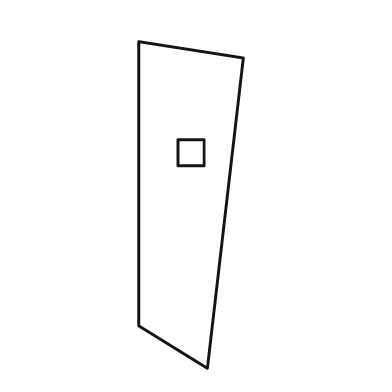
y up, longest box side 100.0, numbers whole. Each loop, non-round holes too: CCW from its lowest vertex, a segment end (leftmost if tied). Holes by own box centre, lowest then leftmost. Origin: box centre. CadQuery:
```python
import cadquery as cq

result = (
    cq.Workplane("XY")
    .moveTo(5.0, -50.0)
    .lineTo(16.0, 45.0)
    .lineTo(-16.0, 50.0)
    .lineTo(-16.0, -37.0)
    .close()
    .moveTo(-4.0, 12.0)
    .lineTo(4.0, 12.0)
    .lineTo(4.0, 20.0)
    .lineTo(-4.0, 20.0)
    .close()
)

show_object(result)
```